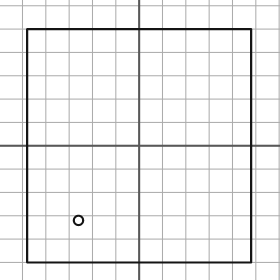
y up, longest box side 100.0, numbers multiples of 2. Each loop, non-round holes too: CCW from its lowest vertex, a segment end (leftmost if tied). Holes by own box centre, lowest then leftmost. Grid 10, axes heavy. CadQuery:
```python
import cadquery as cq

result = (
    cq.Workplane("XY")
    .moveTo(-48.0, -50.0)
    .lineTo(48.0, -50.0)
    .lineTo(48.0, 50.0)
    .lineTo(-48.0, 50.0)
    .close()
    .moveTo(-26.0, -32.0)
    .circle(2.0)
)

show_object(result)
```